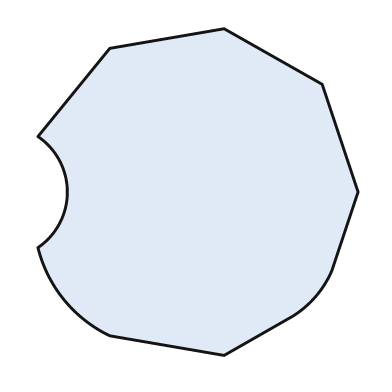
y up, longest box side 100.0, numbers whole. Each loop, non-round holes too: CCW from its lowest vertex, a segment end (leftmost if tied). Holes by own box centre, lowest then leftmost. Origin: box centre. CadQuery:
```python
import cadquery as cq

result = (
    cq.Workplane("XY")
    .moveTo(8.0, -50.0)
    .lineTo(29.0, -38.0)
    .threePointArc((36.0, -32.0), (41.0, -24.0))
    .lineTo(49.0, 0.0)
    .lineTo(38.0, 33.0)
    .lineTo(8.0, 50.0)
    .lineTo(-27.0, 44.0)
    .lineTo(-49.0, 17.0)
    .threePointArc((-40.0, 0.0), (-49.0, -17.0))
    .threePointArc((-41.0, -33.0), (-27.0, -44.0))
    .close()
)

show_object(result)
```